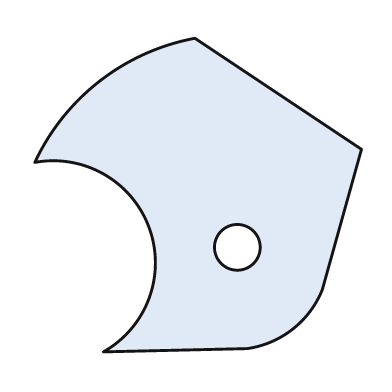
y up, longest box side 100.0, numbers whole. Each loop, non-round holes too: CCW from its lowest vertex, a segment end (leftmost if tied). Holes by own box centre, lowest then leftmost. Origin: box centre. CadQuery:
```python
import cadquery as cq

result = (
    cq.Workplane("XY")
    .moveTo(-29.0, -48.0)
    .lineTo(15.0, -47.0)
    .threePointArc((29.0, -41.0), (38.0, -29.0))
    .lineTo(50.0, 14.0)
    .lineTo(-1.0, 48.0)
    .threePointArc((-30.0, 35.0), (-50.0, 10.0))
    .threePointArc((-15.0, -10.0), (-29.0, -48.0))
    .close()
    .moveTo(12.0, -16.0)
    .circle(7.0)
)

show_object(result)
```